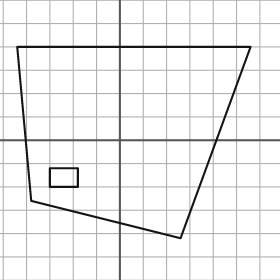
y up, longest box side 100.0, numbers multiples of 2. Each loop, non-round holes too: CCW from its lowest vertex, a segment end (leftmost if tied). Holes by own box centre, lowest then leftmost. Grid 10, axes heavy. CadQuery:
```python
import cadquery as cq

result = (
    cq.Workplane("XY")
    .moveTo(26.0, -42.0)
    .lineTo(56.0, 40.0)
    .lineTo(-44.0, 40.0)
    .lineTo(-38.0, -26.0)
    .close()
    .moveTo(-30.0, -20.0)
    .lineTo(-18.0, -20.0)
    .lineTo(-18.0, -12.0)
    .lineTo(-30.0, -12.0)
    .close()
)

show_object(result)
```